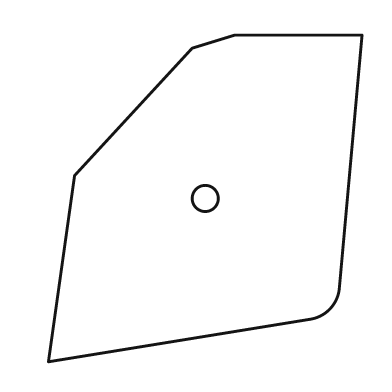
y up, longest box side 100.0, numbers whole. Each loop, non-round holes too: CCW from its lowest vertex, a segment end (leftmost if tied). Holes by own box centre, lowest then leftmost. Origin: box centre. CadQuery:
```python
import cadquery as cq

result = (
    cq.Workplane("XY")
    .moveTo(-48.0, -50.0)
    .lineTo(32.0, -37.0)
    .threePointArc((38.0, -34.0), (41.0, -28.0))
    .lineTo(48.0, 50.0)
    .lineTo(9.0, 50.0)
    .lineTo(-4.0, 46.0)
    .lineTo(-40.0, 7.0)
    .close()
    .moveTo(0.0, 0.0)
    .circle(4.0)
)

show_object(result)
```